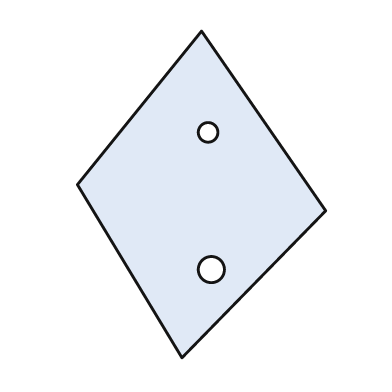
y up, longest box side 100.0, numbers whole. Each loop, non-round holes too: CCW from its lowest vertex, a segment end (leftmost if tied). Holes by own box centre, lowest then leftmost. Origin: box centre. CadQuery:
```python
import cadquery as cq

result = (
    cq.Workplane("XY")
    .moveTo(-6.0, -50.0)
    .lineTo(38.0, -5.0)
    .lineTo(0.0, 50.0)
    .lineTo(-38.0, 3.0)
    .close()
    .moveTo(3.0, -23.0)
    .circle(4.0)
    .moveTo(2.0, 19.0)
    .circle(3.0)
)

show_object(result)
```